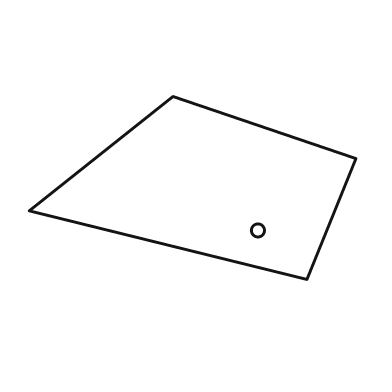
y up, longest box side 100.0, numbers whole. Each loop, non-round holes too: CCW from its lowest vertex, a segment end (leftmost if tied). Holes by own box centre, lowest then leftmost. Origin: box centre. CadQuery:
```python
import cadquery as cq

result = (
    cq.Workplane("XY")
    .moveTo(35.0, -28.0)
    .lineTo(50.0, 9.0)
    .lineTo(-6.0, 28.0)
    .lineTo(-50.0, -7.0)
    .close()
    .moveTo(20.0, -13.0)
    .circle(2.0)
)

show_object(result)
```